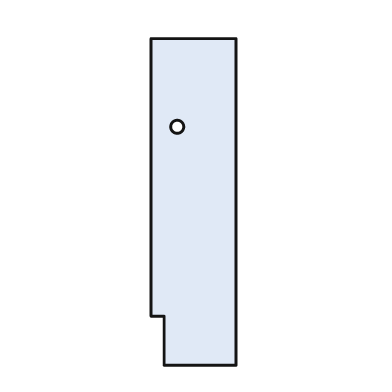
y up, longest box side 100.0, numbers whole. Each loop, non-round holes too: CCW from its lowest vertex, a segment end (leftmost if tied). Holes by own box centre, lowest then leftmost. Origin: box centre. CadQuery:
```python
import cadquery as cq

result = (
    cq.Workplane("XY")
    .moveTo(-9.0, -50.0)
    .lineTo(13.0, -50.0)
    .lineTo(13.0, 50.0)
    .lineTo(-13.0, 50.0)
    .lineTo(-13.0, -35.0)
    .lineTo(-9.0, -35.0)
    .close()
    .moveTo(-5.0, 23.0)
    .circle(2.0)
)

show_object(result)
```